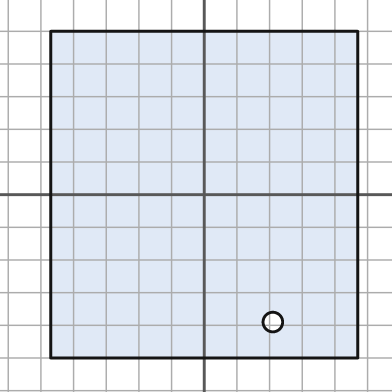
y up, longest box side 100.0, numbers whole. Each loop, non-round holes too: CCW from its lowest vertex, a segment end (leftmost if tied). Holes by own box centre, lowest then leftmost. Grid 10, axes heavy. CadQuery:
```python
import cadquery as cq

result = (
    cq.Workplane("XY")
    .moveTo(-47.0, -50.0)
    .lineTo(47.0, -50.0)
    .lineTo(47.0, 50.0)
    .lineTo(-47.0, 50.0)
    .close()
    .moveTo(21.0, -39.0)
    .circle(3.0)
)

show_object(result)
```